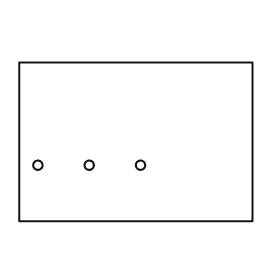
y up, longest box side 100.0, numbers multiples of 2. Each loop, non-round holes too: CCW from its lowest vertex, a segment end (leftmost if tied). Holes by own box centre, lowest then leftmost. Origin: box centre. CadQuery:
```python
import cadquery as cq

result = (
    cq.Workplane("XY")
    .moveTo(-50.0, -34.0)
    .lineTo(50.0, -34.0)
    .lineTo(50.0, 34.0)
    .lineTo(-50.0, 34.0)
    .close()
    .moveTo(-42.0, -10.0)
    .circle(2.0)
    .moveTo(-20.0, -10.0)
    .circle(2.0)
    .moveTo(2.0, -10.0)
    .circle(2.0)
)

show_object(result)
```